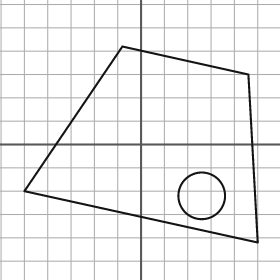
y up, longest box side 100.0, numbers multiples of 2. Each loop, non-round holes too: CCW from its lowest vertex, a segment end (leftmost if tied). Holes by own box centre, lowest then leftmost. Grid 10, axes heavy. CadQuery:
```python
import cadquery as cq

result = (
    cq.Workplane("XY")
    .moveTo(50.0, -42.0)
    .lineTo(46.0, 30.0)
    .lineTo(-8.0, 42.0)
    .lineTo(-50.0, -20.0)
    .close()
    .moveTo(26.0, -22.0)
    .circle(10.0)
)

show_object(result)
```